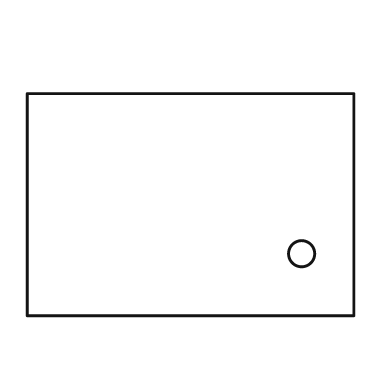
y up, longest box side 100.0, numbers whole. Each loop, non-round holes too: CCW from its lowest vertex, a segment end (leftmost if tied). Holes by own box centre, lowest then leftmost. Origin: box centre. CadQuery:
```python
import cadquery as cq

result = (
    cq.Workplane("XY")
    .moveTo(-50.0, -34.0)
    .lineTo(50.0, -34.0)
    .lineTo(50.0, 34.0)
    .lineTo(-50.0, 34.0)
    .close()
    .moveTo(34.0, -15.0)
    .circle(4.0)
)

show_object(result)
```